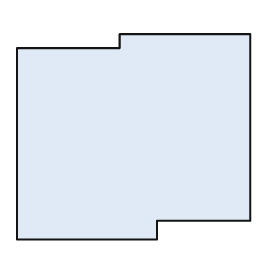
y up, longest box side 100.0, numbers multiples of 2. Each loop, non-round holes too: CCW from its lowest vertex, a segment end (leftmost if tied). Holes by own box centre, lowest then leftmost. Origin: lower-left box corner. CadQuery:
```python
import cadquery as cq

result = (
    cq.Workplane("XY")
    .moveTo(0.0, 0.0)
    .lineTo(60.0, 0.0)
    .lineTo(60.0, 8.0)
    .lineTo(100.0, 8.0)
    .lineTo(100.0, 88.0)
    .lineTo(44.0, 88.0)
    .lineTo(44.0, 82.0)
    .lineTo(0.0, 82.0)
    .close()
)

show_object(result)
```